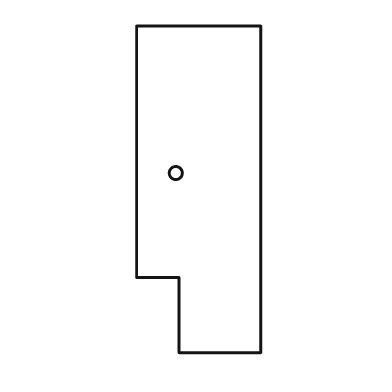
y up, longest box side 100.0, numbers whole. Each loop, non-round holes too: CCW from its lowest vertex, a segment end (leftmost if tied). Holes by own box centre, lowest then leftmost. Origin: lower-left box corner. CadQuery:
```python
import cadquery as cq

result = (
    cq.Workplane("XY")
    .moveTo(13.0, 0.0)
    .lineTo(38.0, 0.0)
    .lineTo(38.0, 100.0)
    .lineTo(0.0, 100.0)
    .lineTo(0.0, 23.0)
    .lineTo(13.0, 23.0)
    .close()
    .moveTo(12.0, 55.0)
    .circle(2.0)
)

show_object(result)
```